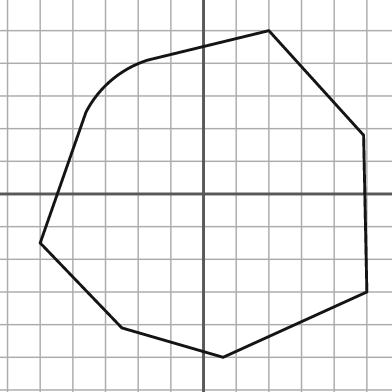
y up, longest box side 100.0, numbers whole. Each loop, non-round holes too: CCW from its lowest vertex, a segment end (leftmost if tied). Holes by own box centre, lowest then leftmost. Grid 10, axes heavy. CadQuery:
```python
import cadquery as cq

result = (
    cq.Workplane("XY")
    .moveTo(6.0, -50.0)
    .lineTo(50.0, -30.0)
    .lineTo(49.0, 18.0)
    .lineTo(20.0, 50.0)
    .lineTo(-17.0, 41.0)
    .threePointArc((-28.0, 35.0), (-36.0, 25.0))
    .lineTo(-50.0, -15.0)
    .lineTo(-25.0, -41.0)
    .close()
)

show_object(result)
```